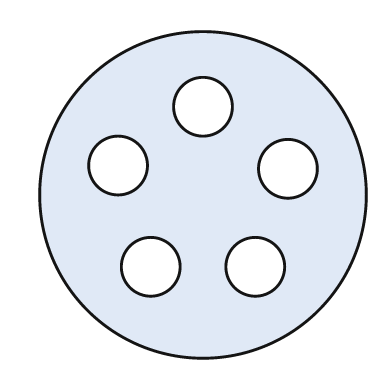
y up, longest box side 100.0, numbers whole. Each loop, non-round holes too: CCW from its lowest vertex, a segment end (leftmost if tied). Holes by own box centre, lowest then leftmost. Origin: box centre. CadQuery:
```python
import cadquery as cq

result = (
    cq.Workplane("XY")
    .moveTo(0.0, 0.0)
    .circle(50.0)
    .moveTo(-16.0, -22.0)
    .circle(9.0)
    .moveTo(16.0, -22.0)
    .circle(9.0)
    .moveTo(26.0, 8.0)
    .circle(9.0)
    .moveTo(-26.0, 9.0)
    .circle(9.0)
    .moveTo(0.0, 27.0)
    .circle(9.0)
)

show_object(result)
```